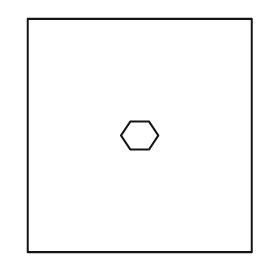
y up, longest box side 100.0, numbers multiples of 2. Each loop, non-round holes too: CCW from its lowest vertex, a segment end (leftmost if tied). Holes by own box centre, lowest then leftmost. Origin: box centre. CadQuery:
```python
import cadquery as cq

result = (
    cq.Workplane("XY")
    .moveTo(-48.0, -50.0)
    .lineTo(48.0, -50.0)
    .lineTo(48.0, 50.0)
    .lineTo(-48.0, 50.0)
    .close()
    .moveTo(-4.0, -6.0)
    .lineTo(4.0, -6.0)
    .lineTo(8.0, 0.0)
    .lineTo(4.0, 6.0)
    .lineTo(-4.0, 6.0)
    .lineTo(-8.0, 0.0)
    .close()
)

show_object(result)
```